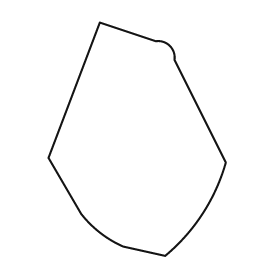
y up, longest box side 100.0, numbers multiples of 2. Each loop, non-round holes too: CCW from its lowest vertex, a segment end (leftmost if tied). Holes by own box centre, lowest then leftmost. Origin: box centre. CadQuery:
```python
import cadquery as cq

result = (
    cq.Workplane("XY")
    .moveTo(12.0, -50.0)
    .threePointArc((28.0, -32.0), (38.0, -10.0))
    .lineTo(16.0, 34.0)
    .threePointArc((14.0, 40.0), (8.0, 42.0))
    .lineTo(-16.0, 50.0)
    .lineTo(-38.0, -8.0)
    .lineTo(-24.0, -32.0)
    .threePointArc((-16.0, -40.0), (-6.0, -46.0))
    .close()
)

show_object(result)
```